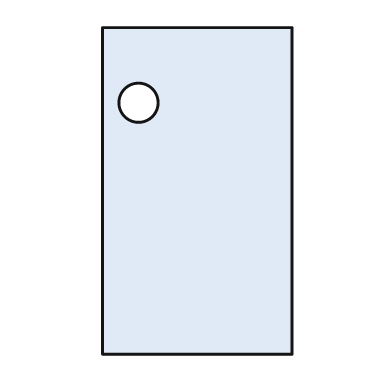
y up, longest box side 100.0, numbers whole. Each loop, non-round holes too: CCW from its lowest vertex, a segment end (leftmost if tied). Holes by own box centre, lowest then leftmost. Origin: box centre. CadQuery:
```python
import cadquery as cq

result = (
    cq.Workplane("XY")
    .moveTo(-29.0, -50.0)
    .lineTo(29.0, -50.0)
    .lineTo(29.0, 50.0)
    .lineTo(-29.0, 50.0)
    .close()
    .moveTo(-18.0, 27.0)
    .circle(6.0)
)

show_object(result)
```